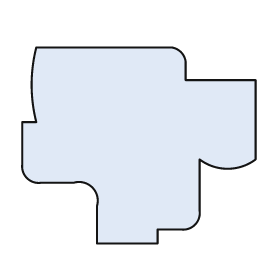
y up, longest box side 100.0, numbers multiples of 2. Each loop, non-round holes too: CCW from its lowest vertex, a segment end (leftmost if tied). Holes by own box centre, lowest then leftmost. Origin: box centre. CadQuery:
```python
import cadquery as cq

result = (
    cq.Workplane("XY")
    .moveTo(-18.0, -42.0)
    .lineTo(8.0, -42.0)
    .lineTo(8.0, -36.0)
    .lineTo(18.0, -36.0)
    .threePointArc((24.0, -34.0), (26.0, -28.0))
    .lineTo(26.0, -6.0)
    .threePointArc((38.0, -10.0), (50.0, -6.0))
    .lineTo(50.0, 28.0)
    .lineTo(20.0, 28.0)
    .lineTo(20.0, 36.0)
    .threePointArc((18.0, 40.0), (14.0, 42.0))
    .lineTo(-44.0, 42.0)
    .threePointArc((-46.0, 26.0), (-44.0, 10.0))
    .lineTo(-50.0, 10.0)
    .lineTo(-50.0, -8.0)
    .threePointArc((-48.0, -14.0), (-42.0, -16.0))
    .lineTo(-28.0, -16.0)
    .threePointArc((-20.0, -18.0), (-18.0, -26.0))
    .close()
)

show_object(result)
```